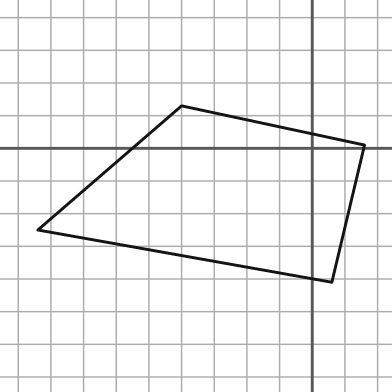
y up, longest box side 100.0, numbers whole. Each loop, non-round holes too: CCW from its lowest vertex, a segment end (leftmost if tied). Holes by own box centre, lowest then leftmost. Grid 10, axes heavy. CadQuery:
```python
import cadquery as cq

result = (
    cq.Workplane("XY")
    .moveTo(6.0, -41.0)
    .lineTo(16.0, 1.0)
    .lineTo(-40.0, 13.0)
    .lineTo(-84.0, -25.0)
    .close()
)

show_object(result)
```